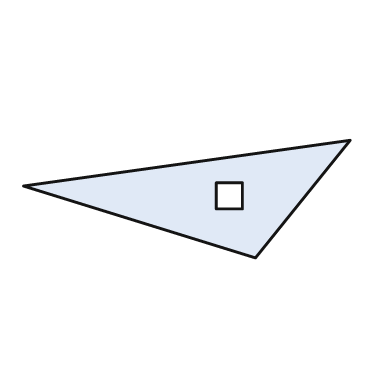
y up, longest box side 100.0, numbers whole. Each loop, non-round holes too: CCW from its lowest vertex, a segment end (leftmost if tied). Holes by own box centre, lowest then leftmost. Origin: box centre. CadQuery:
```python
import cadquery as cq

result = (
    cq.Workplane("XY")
    .moveTo(21.0, -18.0)
    .lineTo(50.0, 18.0)
    .lineTo(-50.0, 4.0)
    .close()
    .moveTo(9.0, -3.0)
    .lineTo(17.0, -3.0)
    .lineTo(17.0, 5.0)
    .lineTo(9.0, 5.0)
    .close()
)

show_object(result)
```